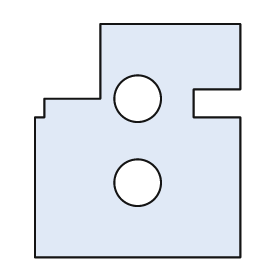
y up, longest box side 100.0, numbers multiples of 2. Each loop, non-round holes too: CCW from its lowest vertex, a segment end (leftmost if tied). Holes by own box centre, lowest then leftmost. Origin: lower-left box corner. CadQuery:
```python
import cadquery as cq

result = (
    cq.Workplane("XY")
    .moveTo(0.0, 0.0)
    .lineTo(88.0, 0.0)
    .lineTo(88.0, 60.0)
    .lineTo(68.0, 60.0)
    .lineTo(68.0, 72.0)
    .lineTo(88.0, 72.0)
    .lineTo(88.0, 100.0)
    .lineTo(28.0, 100.0)
    .lineTo(28.0, 68.0)
    .lineTo(4.0, 68.0)
    .lineTo(4.0, 60.0)
    .lineTo(0.0, 60.0)
    .close()
    .moveTo(44.0, 32.0)
    .circle(10.0)
    .moveTo(44.0, 68.0)
    .circle(10.0)
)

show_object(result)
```